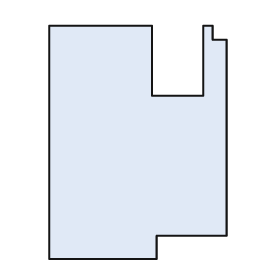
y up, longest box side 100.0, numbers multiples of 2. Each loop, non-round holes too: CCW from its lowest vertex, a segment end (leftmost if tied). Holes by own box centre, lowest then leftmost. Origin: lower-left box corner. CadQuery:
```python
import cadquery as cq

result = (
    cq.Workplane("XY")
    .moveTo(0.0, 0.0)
    .lineTo(46.0, 0.0)
    .lineTo(46.0, 10.0)
    .lineTo(76.0, 10.0)
    .lineTo(76.0, 94.0)
    .lineTo(70.0, 94.0)
    .lineTo(70.0, 100.0)
    .lineTo(66.0, 100.0)
    .lineTo(66.0, 70.0)
    .lineTo(44.0, 70.0)
    .lineTo(44.0, 100.0)
    .lineTo(0.0, 100.0)
    .close()
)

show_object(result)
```